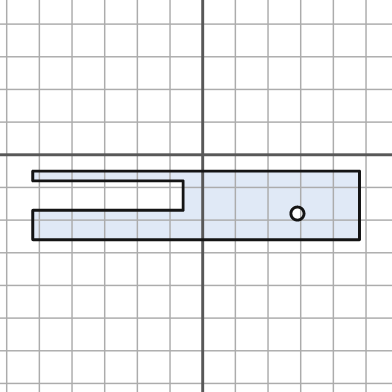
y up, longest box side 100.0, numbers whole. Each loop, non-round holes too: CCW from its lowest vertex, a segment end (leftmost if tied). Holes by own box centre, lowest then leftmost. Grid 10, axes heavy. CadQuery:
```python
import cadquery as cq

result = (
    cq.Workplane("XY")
    .moveTo(-52.0, -26.0)
    .lineTo(48.0, -26.0)
    .lineTo(48.0, -5.0)
    .lineTo(-52.0, -5.0)
    .lineTo(-52.0, -8.0)
    .lineTo(-6.0, -8.0)
    .lineTo(-6.0, -17.0)
    .lineTo(-52.0, -17.0)
    .close()
    .moveTo(29.0, -18.0)
    .circle(2.0)
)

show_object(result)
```